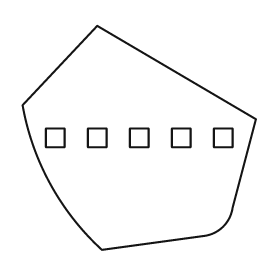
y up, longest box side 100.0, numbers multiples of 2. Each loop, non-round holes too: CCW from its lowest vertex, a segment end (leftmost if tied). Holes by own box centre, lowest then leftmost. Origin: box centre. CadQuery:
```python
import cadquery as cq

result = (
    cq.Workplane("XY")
    .moveTo(-16.0, -48.0)
    .lineTo(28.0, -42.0)
    .threePointArc((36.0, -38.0), (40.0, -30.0))
    .lineTo(50.0, 8.0)
    .lineTo(-18.0, 48.0)
    .lineTo(-50.0, 14.0)
    .threePointArc((-38.0, -20.0), (-16.0, -48.0))
    .close()
    .moveTo(-40.0, -4.0)
    .lineTo(-32.0, -4.0)
    .lineTo(-32.0, 4.0)
    .lineTo(-40.0, 4.0)
    .close()
    .moveTo(-22.0, -4.0)
    .lineTo(-14.0, -4.0)
    .lineTo(-14.0, 4.0)
    .lineTo(-22.0, 4.0)
    .close()
    .moveTo(-4.0, -4.0)
    .lineTo(4.0, -4.0)
    .lineTo(4.0, 4.0)
    .lineTo(-4.0, 4.0)
    .close()
    .moveTo(14.0, -4.0)
    .lineTo(22.0, -4.0)
    .lineTo(22.0, 4.0)
    .lineTo(14.0, 4.0)
    .close()
    .moveTo(32.0, -4.0)
    .lineTo(40.0, -4.0)
    .lineTo(40.0, 4.0)
    .lineTo(32.0, 4.0)
    .close()
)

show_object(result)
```